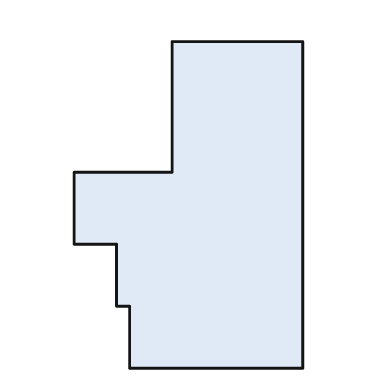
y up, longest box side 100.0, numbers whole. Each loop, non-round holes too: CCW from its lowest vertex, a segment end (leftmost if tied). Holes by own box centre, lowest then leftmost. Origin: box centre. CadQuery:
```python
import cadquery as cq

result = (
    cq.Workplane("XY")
    .moveTo(-18.0, -50.0)
    .lineTo(35.0, -50.0)
    .lineTo(35.0, 50.0)
    .lineTo(-5.0, 50.0)
    .lineTo(-5.0, 10.0)
    .lineTo(-35.0, 10.0)
    .lineTo(-35.0, -12.0)
    .lineTo(-22.0, -12.0)
    .lineTo(-22.0, -31.0)
    .lineTo(-18.0, -31.0)
    .close()
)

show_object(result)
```